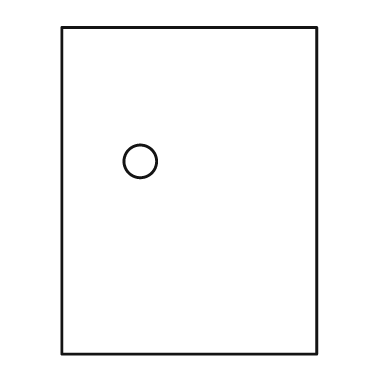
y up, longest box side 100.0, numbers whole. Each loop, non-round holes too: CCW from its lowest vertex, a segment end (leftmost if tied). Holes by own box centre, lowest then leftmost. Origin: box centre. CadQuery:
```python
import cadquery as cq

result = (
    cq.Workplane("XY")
    .moveTo(-39.0, -50.0)
    .lineTo(39.0, -50.0)
    .lineTo(39.0, 50.0)
    .lineTo(-39.0, 50.0)
    .close()
    .moveTo(-15.0, 9.0)
    .circle(5.0)
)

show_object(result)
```